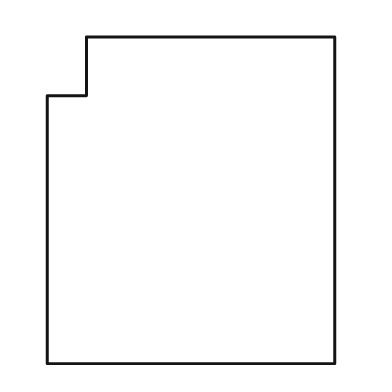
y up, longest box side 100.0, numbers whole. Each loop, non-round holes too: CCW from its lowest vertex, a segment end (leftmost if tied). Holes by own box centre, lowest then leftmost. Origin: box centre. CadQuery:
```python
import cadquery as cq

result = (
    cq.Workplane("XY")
    .moveTo(-44.0, -50.0)
    .lineTo(44.0, -50.0)
    .lineTo(44.0, 50.0)
    .lineTo(-32.0, 50.0)
    .lineTo(-32.0, 32.0)
    .lineTo(-44.0, 32.0)
    .close()
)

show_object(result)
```